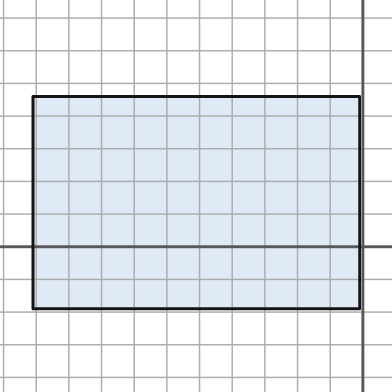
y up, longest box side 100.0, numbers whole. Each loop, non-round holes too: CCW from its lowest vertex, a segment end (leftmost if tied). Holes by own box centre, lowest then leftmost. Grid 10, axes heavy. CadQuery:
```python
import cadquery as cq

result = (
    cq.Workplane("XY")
    .moveTo(-101.0, -19.0)
    .lineTo(-1.0, -19.0)
    .lineTo(-1.0, 46.0)
    .lineTo(-101.0, 46.0)
    .close()
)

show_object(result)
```